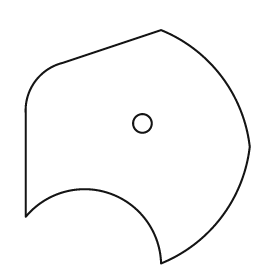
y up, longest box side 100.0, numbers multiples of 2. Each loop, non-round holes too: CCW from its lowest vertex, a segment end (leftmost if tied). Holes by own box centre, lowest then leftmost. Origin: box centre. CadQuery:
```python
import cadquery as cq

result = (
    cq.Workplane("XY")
    .moveTo(10.0, -50.0)
    .threePointArc((36.0, -30.0), (48.0, 0.0))
    .threePointArc((36.0, 30.0), (10.0, 50.0))
    .lineTo(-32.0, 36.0)
    .threePointArc((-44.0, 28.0), (-48.0, 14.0))
    .lineTo(-48.0, -30.0)
    .threePointArc((-12.0, -20.0), (10.0, -50.0))
    .close()
    .moveTo(2.0, 10.0)
    .circle(4.0)
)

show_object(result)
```